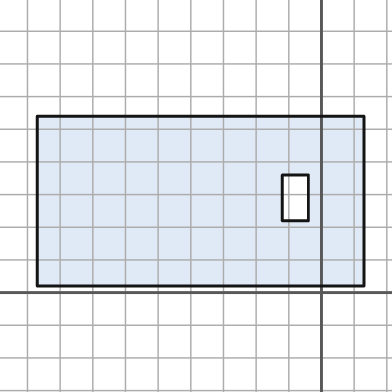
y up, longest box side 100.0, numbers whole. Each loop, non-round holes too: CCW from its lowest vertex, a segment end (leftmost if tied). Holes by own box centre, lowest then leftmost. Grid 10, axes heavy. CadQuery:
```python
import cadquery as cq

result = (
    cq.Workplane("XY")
    .moveTo(-87.0, 2.0)
    .lineTo(13.0, 2.0)
    .lineTo(13.0, 54.0)
    .lineTo(-87.0, 54.0)
    .close()
    .moveTo(-12.0, 22.0)
    .lineTo(-4.0, 22.0)
    .lineTo(-4.0, 36.0)
    .lineTo(-12.0, 36.0)
    .close()
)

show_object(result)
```